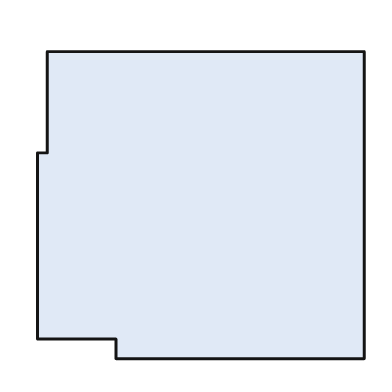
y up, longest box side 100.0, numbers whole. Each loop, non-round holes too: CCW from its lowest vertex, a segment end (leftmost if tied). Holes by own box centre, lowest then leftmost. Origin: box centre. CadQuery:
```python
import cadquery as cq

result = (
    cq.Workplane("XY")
    .moveTo(-26.0, -47.0)
    .lineTo(50.0, -47.0)
    .lineTo(50.0, 47.0)
    .lineTo(-47.0, 47.0)
    .lineTo(-47.0, 16.0)
    .lineTo(-50.0, 16.0)
    .lineTo(-50.0, -41.0)
    .lineTo(-26.0, -41.0)
    .close()
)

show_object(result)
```